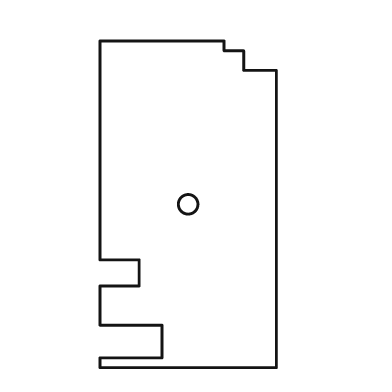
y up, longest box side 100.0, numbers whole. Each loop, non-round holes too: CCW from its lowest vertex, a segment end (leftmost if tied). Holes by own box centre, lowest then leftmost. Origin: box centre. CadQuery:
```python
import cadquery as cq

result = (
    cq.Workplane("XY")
    .moveTo(-27.0, -50.0)
    .lineTo(27.0, -50.0)
    .lineTo(27.0, 41.0)
    .lineTo(17.0, 41.0)
    .lineTo(17.0, 47.0)
    .lineTo(11.0, 47.0)
    .lineTo(11.0, 50.0)
    .lineTo(-27.0, 50.0)
    .lineTo(-27.0, -17.0)
    .lineTo(-15.0, -17.0)
    .lineTo(-15.0, -25.0)
    .lineTo(-27.0, -25.0)
    .lineTo(-27.0, -37.0)
    .lineTo(-8.0, -37.0)
    .lineTo(-8.0, -47.0)
    .lineTo(-27.0, -47.0)
    .close()
    .moveTo(0.0, 0.0)
    .circle(3.0)
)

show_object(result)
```